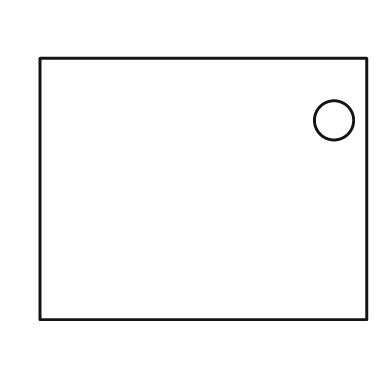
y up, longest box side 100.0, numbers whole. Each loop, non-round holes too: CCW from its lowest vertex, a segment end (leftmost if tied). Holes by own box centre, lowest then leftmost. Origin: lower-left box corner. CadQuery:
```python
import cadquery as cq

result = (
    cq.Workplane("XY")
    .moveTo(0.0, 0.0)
    .lineTo(100.0, 0.0)
    .lineTo(100.0, 80.0)
    .lineTo(0.0, 80.0)
    .close()
    .moveTo(90.0, 61.0)
    .circle(6.0)
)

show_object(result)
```